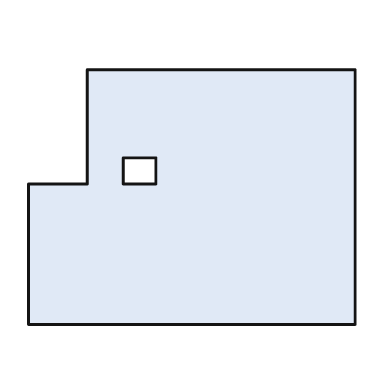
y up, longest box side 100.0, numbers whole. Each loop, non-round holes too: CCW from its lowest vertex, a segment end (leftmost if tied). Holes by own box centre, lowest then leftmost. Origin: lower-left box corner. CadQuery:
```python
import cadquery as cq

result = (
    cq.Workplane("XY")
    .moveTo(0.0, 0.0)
    .lineTo(100.0, 0.0)
    .lineTo(100.0, 78.0)
    .lineTo(18.0, 78.0)
    .lineTo(18.0, 43.0)
    .lineTo(0.0, 43.0)
    .close()
    .moveTo(29.0, 43.0)
    .lineTo(39.0, 43.0)
    .lineTo(39.0, 51.0)
    .lineTo(29.0, 51.0)
    .close()
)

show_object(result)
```